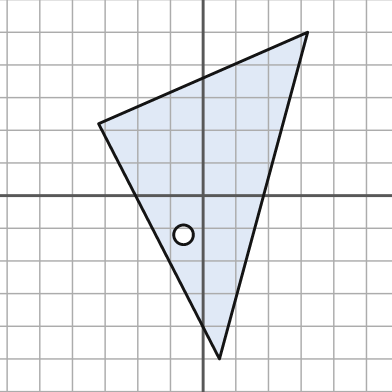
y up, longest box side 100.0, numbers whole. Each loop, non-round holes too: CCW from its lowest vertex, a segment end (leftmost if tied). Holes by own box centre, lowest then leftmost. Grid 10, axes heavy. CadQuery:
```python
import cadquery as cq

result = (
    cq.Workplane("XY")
    .moveTo(5.0, -50.0)
    .lineTo(32.0, 50.0)
    .lineTo(-32.0, 22.0)
    .close()
    .moveTo(-6.0, -12.0)
    .circle(3.0)
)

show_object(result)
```